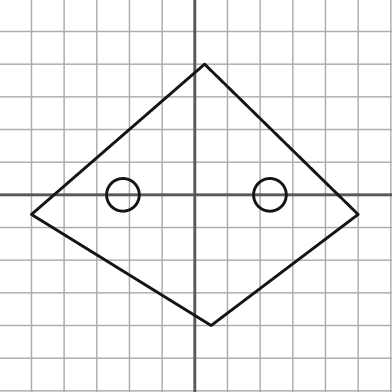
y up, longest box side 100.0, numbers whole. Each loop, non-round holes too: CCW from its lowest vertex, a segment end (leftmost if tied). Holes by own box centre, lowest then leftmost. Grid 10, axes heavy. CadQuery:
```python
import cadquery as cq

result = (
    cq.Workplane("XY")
    .moveTo(5.0, -40.0)
    .lineTo(50.0, -6.0)
    .lineTo(3.0, 40.0)
    .lineTo(-50.0, -6.0)
    .close()
    .moveTo(-22.0, 0.0)
    .circle(5.0)
    .moveTo(23.0, 0.0)
    .circle(5.0)
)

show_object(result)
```